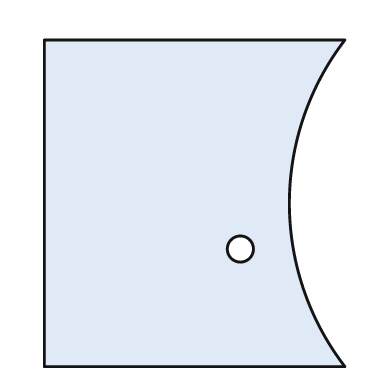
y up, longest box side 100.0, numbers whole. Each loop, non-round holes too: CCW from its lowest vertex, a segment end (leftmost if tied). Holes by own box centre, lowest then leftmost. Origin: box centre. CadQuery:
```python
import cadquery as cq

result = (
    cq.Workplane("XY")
    .moveTo(-46.0, -50.0)
    .lineTo(46.0, -50.0)
    .threePointArc((29.0, 0.0), (46.0, 50.0))
    .lineTo(-46.0, 50.0)
    .close()
    .moveTo(14.0, -14.0)
    .circle(4.0)
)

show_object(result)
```